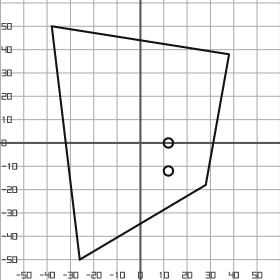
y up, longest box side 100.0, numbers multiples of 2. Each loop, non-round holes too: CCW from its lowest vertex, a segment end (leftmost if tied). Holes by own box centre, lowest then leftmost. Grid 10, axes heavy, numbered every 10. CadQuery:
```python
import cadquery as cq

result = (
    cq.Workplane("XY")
    .moveTo(-26.0, -50.0)
    .lineTo(28.0, -18.0)
    .lineTo(38.0, 38.0)
    .lineTo(-38.0, 50.0)
    .close()
    .moveTo(12.0, -12.0)
    .circle(2.0)
    .moveTo(12.0, 0.0)
    .circle(2.0)
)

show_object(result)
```